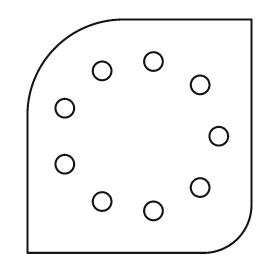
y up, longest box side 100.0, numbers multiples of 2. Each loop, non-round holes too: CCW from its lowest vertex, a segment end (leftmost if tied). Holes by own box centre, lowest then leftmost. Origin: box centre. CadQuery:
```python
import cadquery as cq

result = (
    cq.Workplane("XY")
    .moveTo(-48.0, -50.0)
    .lineTo(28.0, -50.0)
    .threePointArc((42.0, -44.0), (48.0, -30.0))
    .lineTo(48.0, 50.0)
    .lineTo(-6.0, 50.0)
    .threePointArc((-36.0, 38.0), (-48.0, 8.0))
    .close()
    .moveTo(6.0, -32.0)
    .circle(4.0)
    .moveTo(-16.0, -28.0)
    .circle(4.0)
    .moveTo(26.0, -22.0)
    .circle(4.0)
    .moveTo(-32.0, -12.0)
    .circle(4.0)
    .moveTo(34.0, 0.0)
    .circle(4.0)
    .moveTo(-32.0, 12.0)
    .circle(4.0)
    .moveTo(26.0, 22.0)
    .circle(4.0)
    .moveTo(-16.0, 28.0)
    .circle(4.0)
    .moveTo(6.0, 32.0)
    .circle(4.0)
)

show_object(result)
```